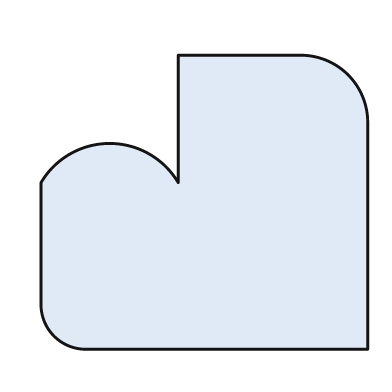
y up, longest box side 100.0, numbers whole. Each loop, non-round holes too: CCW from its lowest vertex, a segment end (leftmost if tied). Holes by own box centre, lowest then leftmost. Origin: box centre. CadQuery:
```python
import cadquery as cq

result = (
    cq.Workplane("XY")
    .moveTo(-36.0, -45.0)
    .lineTo(50.0, -45.0)
    .lineTo(50.0, 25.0)
    .threePointArc((44.0, 39.0), (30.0, 45.0))
    .lineTo(-8.0, 45.0)
    .lineTo(-8.0, 6.0)
    .threePointArc((-29.0, 18.0), (-50.0, 6.0))
    .lineTo(-50.0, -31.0)
    .threePointArc((-46.0, -41.0), (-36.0, -45.0))
    .close()
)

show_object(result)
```